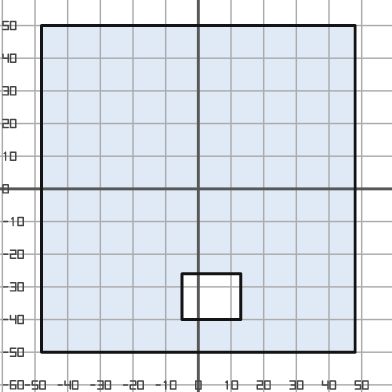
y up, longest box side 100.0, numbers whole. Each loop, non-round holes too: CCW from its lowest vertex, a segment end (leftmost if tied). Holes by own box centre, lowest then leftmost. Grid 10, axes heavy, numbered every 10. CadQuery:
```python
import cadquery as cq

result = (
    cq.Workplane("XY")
    .moveTo(-48.0, -50.0)
    .lineTo(48.0, -50.0)
    .lineTo(48.0, 50.0)
    .lineTo(-48.0, 50.0)
    .close()
    .moveTo(-5.0, -40.0)
    .lineTo(13.0, -40.0)
    .lineTo(13.0, -26.0)
    .lineTo(-5.0, -26.0)
    .close()
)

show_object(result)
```